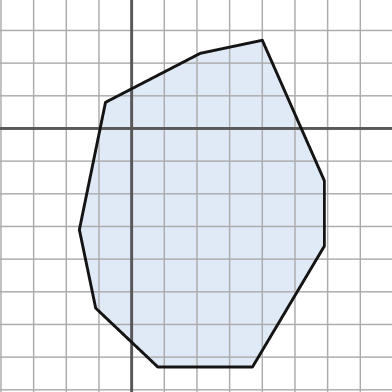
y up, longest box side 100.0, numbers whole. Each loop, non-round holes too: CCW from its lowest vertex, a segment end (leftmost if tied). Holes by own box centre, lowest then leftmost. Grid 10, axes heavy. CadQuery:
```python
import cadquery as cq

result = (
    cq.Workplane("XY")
    .moveTo(8.0, -73.0)
    .lineTo(37.0, -73.0)
    .lineTo(59.0, -36.0)
    .lineTo(59.0, -16.0)
    .lineTo(40.0, 27.0)
    .lineTo(21.0, 23.0)
    .lineTo(-8.0, 8.0)
    .lineTo(-16.0, -31.0)
    .lineTo(-11.0, -55.0)
    .close()
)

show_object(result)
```